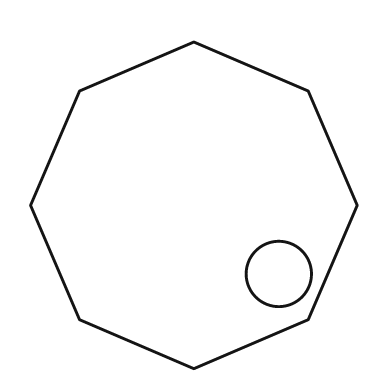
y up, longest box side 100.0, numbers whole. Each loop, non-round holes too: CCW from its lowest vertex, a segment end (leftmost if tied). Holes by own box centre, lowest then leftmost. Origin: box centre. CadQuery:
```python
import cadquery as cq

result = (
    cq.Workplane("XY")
    .moveTo(0.0, -50.0)
    .lineTo(35.0, -35.0)
    .lineTo(50.0, 0.0)
    .lineTo(35.0, 35.0)
    .lineTo(0.0, 50.0)
    .lineTo(-35.0, 35.0)
    .lineTo(-50.0, 0.0)
    .lineTo(-35.0, -35.0)
    .close()
    .moveTo(26.0, -21.0)
    .circle(10.0)
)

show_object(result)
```